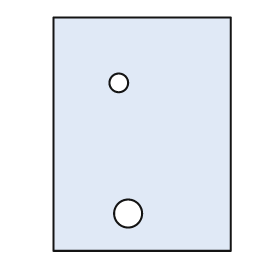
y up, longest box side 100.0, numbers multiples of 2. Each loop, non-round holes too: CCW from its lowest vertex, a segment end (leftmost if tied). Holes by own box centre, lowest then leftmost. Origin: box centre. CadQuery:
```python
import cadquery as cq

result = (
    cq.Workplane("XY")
    .moveTo(-38.0, -50.0)
    .lineTo(38.0, -50.0)
    .lineTo(38.0, 50.0)
    .lineTo(-38.0, 50.0)
    .close()
    .moveTo(-6.0, -34.0)
    .circle(6.0)
    .moveTo(-10.0, 22.0)
    .circle(4.0)
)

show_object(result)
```